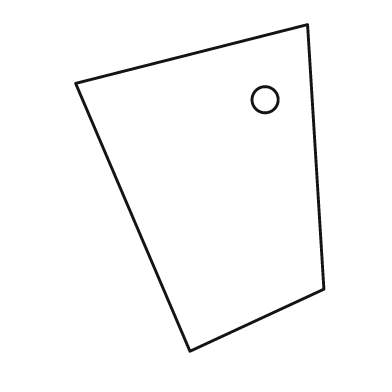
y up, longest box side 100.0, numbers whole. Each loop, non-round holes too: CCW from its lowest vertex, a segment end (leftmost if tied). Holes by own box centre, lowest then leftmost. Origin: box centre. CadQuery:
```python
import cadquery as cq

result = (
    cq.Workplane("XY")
    .moveTo(-3.0, -50.0)
    .lineTo(38.0, -31.0)
    .lineTo(33.0, 50.0)
    .lineTo(-38.0, 32.0)
    .close()
    .moveTo(20.0, 27.0)
    .circle(4.0)
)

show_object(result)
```